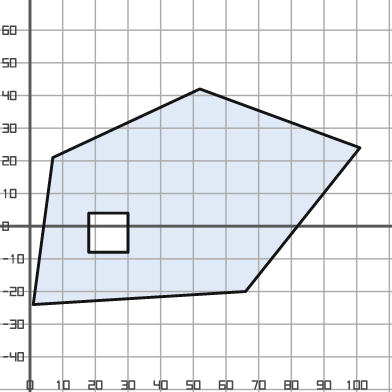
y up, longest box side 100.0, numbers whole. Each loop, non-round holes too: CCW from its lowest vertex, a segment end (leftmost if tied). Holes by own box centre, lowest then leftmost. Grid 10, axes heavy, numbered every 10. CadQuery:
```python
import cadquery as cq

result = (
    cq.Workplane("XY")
    .moveTo(1.0, -24.0)
    .lineTo(66.0, -20.0)
    .lineTo(101.0, 24.0)
    .lineTo(52.0, 42.0)
    .lineTo(7.0, 21.0)
    .close()
    .moveTo(18.0, -8.0)
    .lineTo(30.0, -8.0)
    .lineTo(30.0, 4.0)
    .lineTo(18.0, 4.0)
    .close()
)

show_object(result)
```